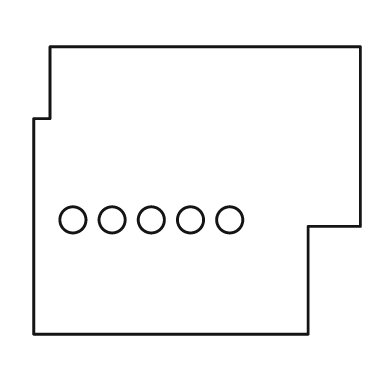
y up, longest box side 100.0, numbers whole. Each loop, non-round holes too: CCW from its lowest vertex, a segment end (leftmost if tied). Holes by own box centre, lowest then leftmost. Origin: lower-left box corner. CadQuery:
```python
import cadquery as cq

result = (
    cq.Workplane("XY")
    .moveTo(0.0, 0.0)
    .lineTo(84.0, 0.0)
    .lineTo(84.0, 33.0)
    .lineTo(100.0, 33.0)
    .lineTo(100.0, 88.0)
    .lineTo(5.0, 88.0)
    .lineTo(5.0, 66.0)
    .lineTo(0.0, 66.0)
    .close()
    .moveTo(12.0, 35.0)
    .circle(4.0)
    .moveTo(24.0, 35.0)
    .circle(4.0)
    .moveTo(36.0, 35.0)
    .circle(4.0)
    .moveTo(48.0, 35.0)
    .circle(4.0)
    .moveTo(60.0, 35.0)
    .circle(4.0)
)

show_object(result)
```